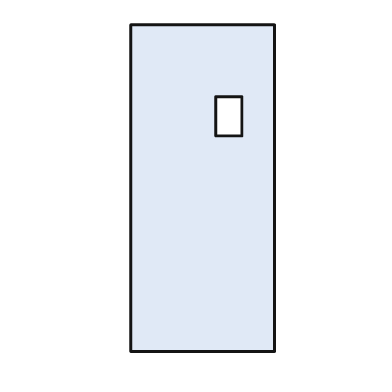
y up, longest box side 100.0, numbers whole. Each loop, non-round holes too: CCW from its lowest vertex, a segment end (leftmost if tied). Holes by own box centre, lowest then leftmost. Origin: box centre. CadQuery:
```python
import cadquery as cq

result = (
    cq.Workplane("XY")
    .moveTo(-22.0, -50.0)
    .lineTo(22.0, -50.0)
    .lineTo(22.0, 50.0)
    .lineTo(-22.0, 50.0)
    .close()
    .moveTo(4.0, 16.0)
    .lineTo(12.0, 16.0)
    .lineTo(12.0, 28.0)
    .lineTo(4.0, 28.0)
    .close()
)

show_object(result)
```